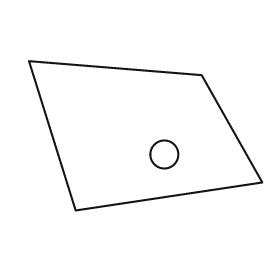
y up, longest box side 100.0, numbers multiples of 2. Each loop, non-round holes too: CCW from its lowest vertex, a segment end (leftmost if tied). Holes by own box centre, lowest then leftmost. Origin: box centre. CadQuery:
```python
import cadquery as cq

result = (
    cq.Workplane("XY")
    .moveTo(-30.0, -32.0)
    .lineTo(50.0, -20.0)
    .lineTo(24.0, 26.0)
    .lineTo(-50.0, 32.0)
    .close()
    .moveTo(8.0, -8.0)
    .circle(6.0)
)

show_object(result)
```